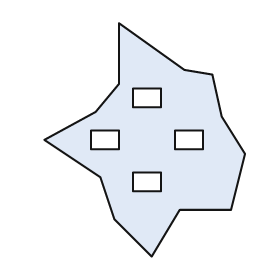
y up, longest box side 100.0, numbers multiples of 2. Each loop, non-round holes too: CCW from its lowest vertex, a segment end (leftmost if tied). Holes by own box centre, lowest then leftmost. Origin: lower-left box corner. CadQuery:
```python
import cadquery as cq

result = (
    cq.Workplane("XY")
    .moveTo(46.0, 0.0)
    .lineTo(58.0, 20.0)
    .lineTo(80.0, 20.0)
    .lineTo(86.0, 44.0)
    .lineTo(76.0, 60.0)
    .lineTo(72.0, 78.0)
    .lineTo(60.0, 80.0)
    .lineTo(32.0, 100.0)
    .lineTo(32.0, 74.0)
    .lineTo(22.0, 62.0)
    .lineTo(0.0, 50.0)
    .lineTo(24.0, 34.0)
    .lineTo(30.0, 16.0)
    .close()
    .moveTo(38.0, 28.0)
    .lineTo(50.0, 28.0)
    .lineTo(50.0, 36.0)
    .lineTo(38.0, 36.0)
    .close()
    .moveTo(20.0, 46.0)
    .lineTo(32.0, 46.0)
    .lineTo(32.0, 54.0)
    .lineTo(20.0, 54.0)
    .close()
    .moveTo(56.0, 46.0)
    .lineTo(68.0, 46.0)
    .lineTo(68.0, 54.0)
    .lineTo(56.0, 54.0)
    .close()
    .moveTo(38.0, 64.0)
    .lineTo(50.0, 64.0)
    .lineTo(50.0, 72.0)
    .lineTo(38.0, 72.0)
    .close()
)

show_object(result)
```